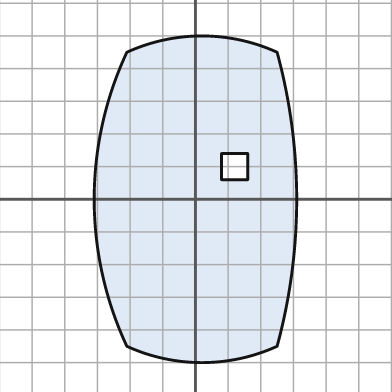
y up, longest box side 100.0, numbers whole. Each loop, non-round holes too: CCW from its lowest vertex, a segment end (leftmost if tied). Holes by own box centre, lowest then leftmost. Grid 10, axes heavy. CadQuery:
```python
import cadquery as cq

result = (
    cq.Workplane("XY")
    .moveTo(-21.0, -45.0)
    .threePointArc((2.0, -50.0), (25.0, -45.0))
    .threePointArc((31.0, 0.0), (25.0, 45.0))
    .threePointArc((2.0, 50.0), (-21.0, 45.0))
    .threePointArc((-31.0, 0.0), (-21.0, -45.0))
    .close()
    .moveTo(8.0, 6.0)
    .lineTo(16.0, 6.0)
    .lineTo(16.0, 14.0)
    .lineTo(8.0, 14.0)
    .close()
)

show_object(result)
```